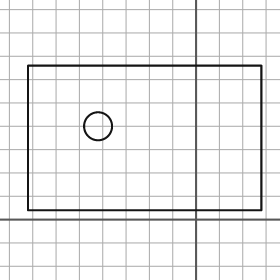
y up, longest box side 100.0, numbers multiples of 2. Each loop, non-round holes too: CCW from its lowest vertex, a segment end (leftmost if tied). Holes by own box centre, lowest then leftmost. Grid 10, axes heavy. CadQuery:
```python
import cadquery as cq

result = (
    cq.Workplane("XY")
    .moveTo(-72.0, 4.0)
    .lineTo(28.0, 4.0)
    .lineTo(28.0, 66.0)
    .lineTo(-72.0, 66.0)
    .close()
    .moveTo(-42.0, 40.0)
    .circle(6.0)
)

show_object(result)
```